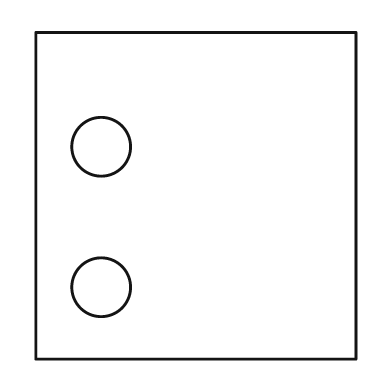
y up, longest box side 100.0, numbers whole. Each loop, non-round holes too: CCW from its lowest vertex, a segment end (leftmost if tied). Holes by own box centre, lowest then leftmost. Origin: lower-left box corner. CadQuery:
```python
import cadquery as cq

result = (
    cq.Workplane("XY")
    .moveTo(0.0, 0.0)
    .lineTo(98.0, 0.0)
    .lineTo(98.0, 100.0)
    .lineTo(0.0, 100.0)
    .close()
    .moveTo(20.0, 22.0)
    .circle(9.0)
    .moveTo(20.0, 65.0)
    .circle(9.0)
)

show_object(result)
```